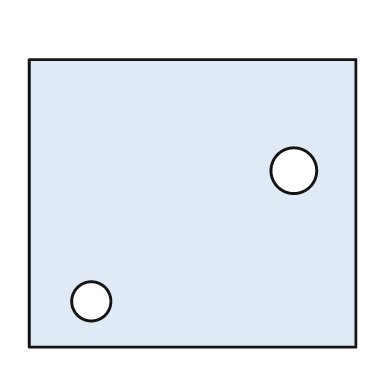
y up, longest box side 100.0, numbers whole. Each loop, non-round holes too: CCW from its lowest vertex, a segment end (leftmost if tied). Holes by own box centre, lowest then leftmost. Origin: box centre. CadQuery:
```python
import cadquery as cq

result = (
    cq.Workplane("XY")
    .moveTo(-50.0, -44.0)
    .lineTo(50.0, -44.0)
    .lineTo(50.0, 44.0)
    .lineTo(-50.0, 44.0)
    .close()
    .moveTo(-31.0, -30.0)
    .circle(6.0)
    .moveTo(31.0, 10.0)
    .circle(7.0)
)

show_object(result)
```